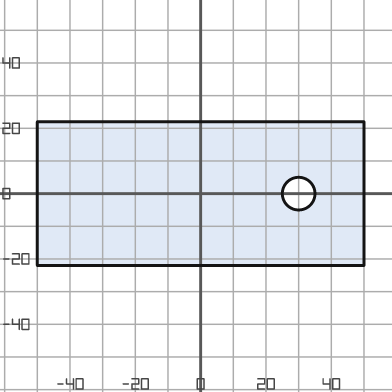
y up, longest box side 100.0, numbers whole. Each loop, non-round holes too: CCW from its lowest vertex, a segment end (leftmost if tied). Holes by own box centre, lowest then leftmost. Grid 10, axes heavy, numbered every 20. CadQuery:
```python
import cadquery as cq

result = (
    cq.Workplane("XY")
    .moveTo(-50.0, -22.0)
    .lineTo(50.0, -22.0)
    .lineTo(50.0, 22.0)
    .lineTo(-50.0, 22.0)
    .close()
    .moveTo(30.0, 0.0)
    .circle(5.0)
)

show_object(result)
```